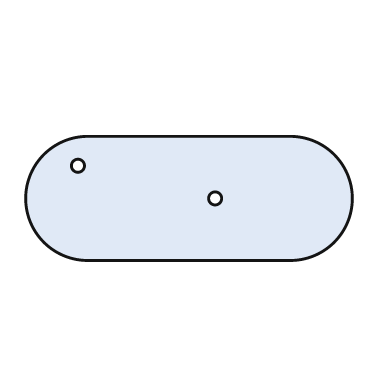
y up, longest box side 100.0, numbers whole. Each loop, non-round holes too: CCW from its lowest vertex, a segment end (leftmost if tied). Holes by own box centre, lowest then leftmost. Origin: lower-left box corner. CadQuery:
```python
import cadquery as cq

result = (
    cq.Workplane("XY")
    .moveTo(19.0, 0.0)
    .lineTo(81.0, 0.0)
    .threePointArc((100.0, 19.0), (81.0, 38.0))
    .lineTo(19.0, 38.0)
    .threePointArc((0.0, 19.0), (19.0, 0.0))
    .close()
    .moveTo(58.0, 19.0)
    .circle(2.0)
    .moveTo(16.0, 29.0)
    .circle(2.0)
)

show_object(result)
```